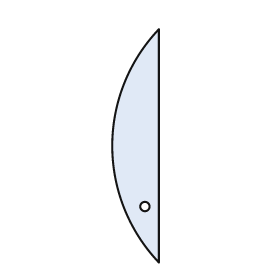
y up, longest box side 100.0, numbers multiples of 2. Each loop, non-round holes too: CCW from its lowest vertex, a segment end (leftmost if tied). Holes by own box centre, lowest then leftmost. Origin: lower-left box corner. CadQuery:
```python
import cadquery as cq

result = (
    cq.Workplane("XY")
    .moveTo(20.0, 0.0)
    .lineTo(20.0, 100.0)
    .threePointArc((0.0, 50.0), (20.0, 0.0))
    .close()
    .moveTo(14.0, 24.0)
    .circle(2.0)
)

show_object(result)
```